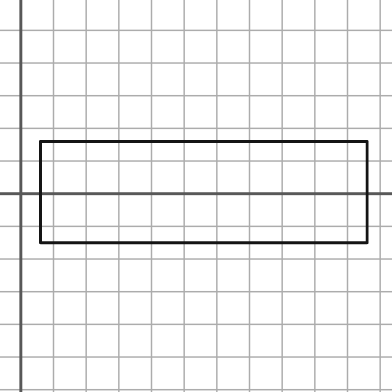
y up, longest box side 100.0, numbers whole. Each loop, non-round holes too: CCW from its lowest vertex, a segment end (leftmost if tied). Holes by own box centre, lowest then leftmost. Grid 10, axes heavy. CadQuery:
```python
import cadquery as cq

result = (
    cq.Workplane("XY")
    .moveTo(6.0, -15.0)
    .lineTo(106.0, -15.0)
    .lineTo(106.0, 16.0)
    .lineTo(6.0, 16.0)
    .close()
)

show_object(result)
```